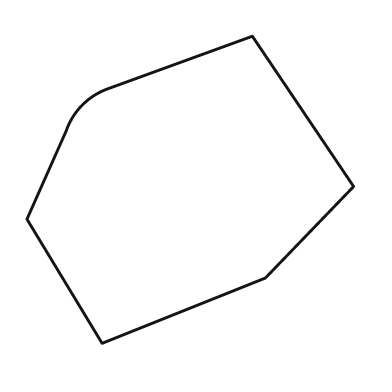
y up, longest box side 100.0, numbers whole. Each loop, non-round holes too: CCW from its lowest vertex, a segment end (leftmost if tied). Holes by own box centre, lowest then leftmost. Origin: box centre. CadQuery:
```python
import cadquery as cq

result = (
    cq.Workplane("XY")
    .moveTo(-27.0, -47.0)
    .lineTo(23.0, -27.0)
    .lineTo(50.0, 1.0)
    .lineTo(19.0, 47.0)
    .lineTo(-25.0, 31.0)
    .threePointArc((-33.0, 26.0), (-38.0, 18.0))
    .lineTo(-50.0, -9.0)
    .close()
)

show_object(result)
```